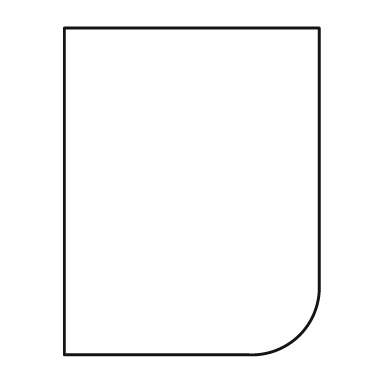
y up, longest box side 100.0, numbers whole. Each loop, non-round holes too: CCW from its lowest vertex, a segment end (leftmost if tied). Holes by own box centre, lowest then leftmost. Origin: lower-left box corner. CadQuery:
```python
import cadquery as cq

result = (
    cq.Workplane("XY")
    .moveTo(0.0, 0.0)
    .lineTo(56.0, 0.0)
    .threePointArc((72.0, 6.0), (78.0, 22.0))
    .lineTo(78.0, 100.0)
    .lineTo(0.0, 100.0)
    .close()
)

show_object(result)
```